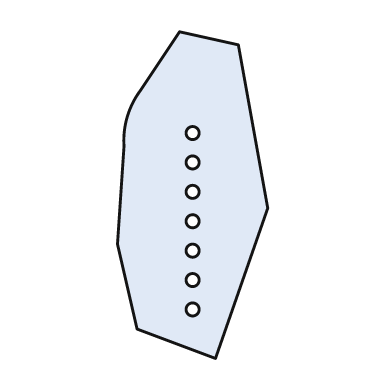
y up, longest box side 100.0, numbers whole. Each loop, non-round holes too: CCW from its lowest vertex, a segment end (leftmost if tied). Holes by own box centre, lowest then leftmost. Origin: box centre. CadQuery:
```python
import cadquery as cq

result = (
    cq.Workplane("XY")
    .moveTo(7.0, -50.0)
    .lineTo(23.0, -4.0)
    .lineTo(14.0, 46.0)
    .lineTo(-4.0, 50.0)
    .lineTo(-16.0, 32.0)
    .threePointArc((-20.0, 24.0), (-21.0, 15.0))
    .lineTo(-23.0, -15.0)
    .lineTo(-17.0, -41.0)
    .close()
    .moveTo(0.0, -35.0)
    .circle(2.0)
    .moveTo(0.0, -26.0)
    .circle(2.0)
    .moveTo(0.0, -17.0)
    .circle(2.0)
    .moveTo(0.0, -8.0)
    .circle(2.0)
    .moveTo(0.0, 1.0)
    .circle(2.0)
    .moveTo(0.0, 10.0)
    .circle(2.0)
    .moveTo(0.0, 19.0)
    .circle(2.0)
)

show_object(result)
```